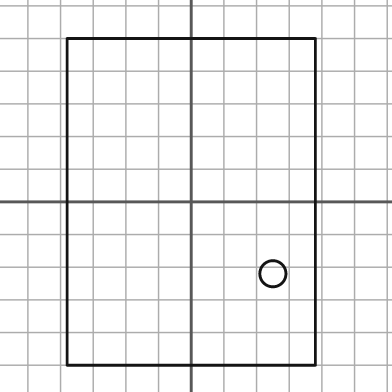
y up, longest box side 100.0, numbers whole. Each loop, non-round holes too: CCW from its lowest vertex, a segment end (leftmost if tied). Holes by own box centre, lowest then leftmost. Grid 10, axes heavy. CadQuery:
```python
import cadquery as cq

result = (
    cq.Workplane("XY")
    .moveTo(-38.0, -50.0)
    .lineTo(38.0, -50.0)
    .lineTo(38.0, 50.0)
    .lineTo(-38.0, 50.0)
    .close()
    .moveTo(25.0, -22.0)
    .circle(4.0)
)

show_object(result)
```